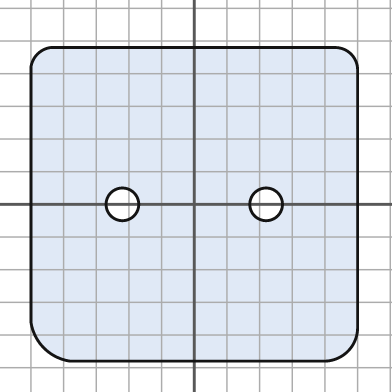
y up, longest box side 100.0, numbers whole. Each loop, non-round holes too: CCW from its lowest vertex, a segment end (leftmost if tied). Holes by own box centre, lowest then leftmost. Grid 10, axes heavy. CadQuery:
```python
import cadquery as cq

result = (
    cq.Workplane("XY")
    .moveTo(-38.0, -48.0)
    .lineTo(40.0, -48.0)
    .threePointArc((47.0, -45.0), (50.0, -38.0))
    .lineTo(50.0, 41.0)
    .threePointArc((48.0, 46.0), (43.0, 48.0))
    .lineTo(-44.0, 48.0)
    .threePointArc((-48.0, 46.0), (-50.0, 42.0))
    .lineTo(-50.0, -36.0)
    .threePointArc((-46.0, -44.0), (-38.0, -48.0))
    .close()
    .moveTo(-22.0, 0.0)
    .circle(5.0)
    .moveTo(22.0, 0.0)
    .circle(5.0)
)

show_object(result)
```